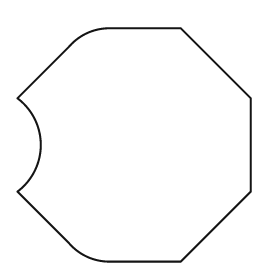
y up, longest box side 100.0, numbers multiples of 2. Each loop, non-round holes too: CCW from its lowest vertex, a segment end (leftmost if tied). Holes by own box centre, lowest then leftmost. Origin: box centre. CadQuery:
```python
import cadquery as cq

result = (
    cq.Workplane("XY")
    .moveTo(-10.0, -50.0)
    .lineTo(20.0, -50.0)
    .lineTo(50.0, -20.0)
    .lineTo(50.0, 20.0)
    .lineTo(20.0, 50.0)
    .lineTo(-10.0, 50.0)
    .threePointArc((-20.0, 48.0), (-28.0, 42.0))
    .lineTo(-50.0, 20.0)
    .threePointArc((-40.0, 0.0), (-50.0, -20.0))
    .lineTo(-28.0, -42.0)
    .threePointArc((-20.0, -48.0), (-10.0, -50.0))
    .close()
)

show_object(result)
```